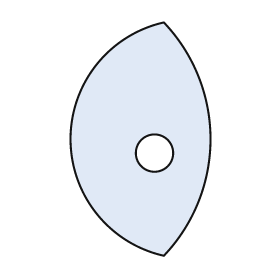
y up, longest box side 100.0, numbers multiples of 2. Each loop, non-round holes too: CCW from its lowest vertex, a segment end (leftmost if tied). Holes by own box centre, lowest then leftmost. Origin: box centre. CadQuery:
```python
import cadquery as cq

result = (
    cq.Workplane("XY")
    .moveTo(10.0, -50.0)
    .threePointArc((30.0, 0.0), (10.0, 50.0))
    .threePointArc((-30.0, 0.0), (10.0, -50.0))
    .close()
    .moveTo(6.0, -6.0)
    .circle(8.0)
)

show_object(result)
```